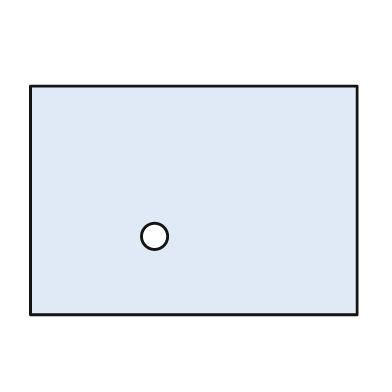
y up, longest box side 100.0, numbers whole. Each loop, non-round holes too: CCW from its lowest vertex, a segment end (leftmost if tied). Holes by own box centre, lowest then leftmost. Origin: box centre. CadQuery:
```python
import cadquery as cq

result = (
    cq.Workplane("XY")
    .moveTo(-50.0, -35.0)
    .lineTo(50.0, -35.0)
    .lineTo(50.0, 35.0)
    .lineTo(-50.0, 35.0)
    .close()
    .moveTo(-12.0, -11.0)
    .circle(4.0)
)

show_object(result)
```